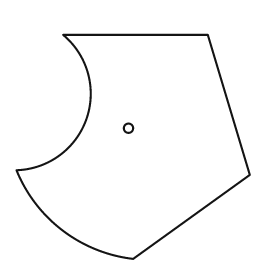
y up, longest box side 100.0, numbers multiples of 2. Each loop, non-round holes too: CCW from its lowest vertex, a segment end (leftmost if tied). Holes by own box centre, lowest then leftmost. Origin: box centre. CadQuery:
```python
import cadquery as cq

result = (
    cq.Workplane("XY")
    .moveTo(0.0, -48.0)
    .lineTo(50.0, -12.0)
    .lineTo(32.0, 48.0)
    .lineTo(-30.0, 48.0)
    .threePointArc((-20.0, 12.0), (-50.0, -10.0))
    .threePointArc((-30.0, -36.0), (0.0, -48.0))
    .close()
    .moveTo(-2.0, 8.0)
    .circle(2.0)
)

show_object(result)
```